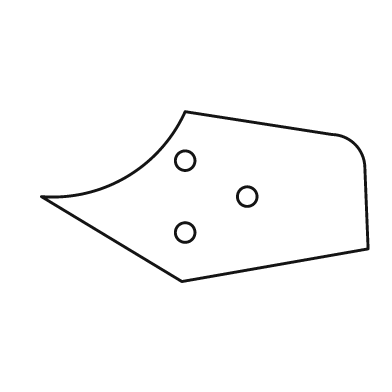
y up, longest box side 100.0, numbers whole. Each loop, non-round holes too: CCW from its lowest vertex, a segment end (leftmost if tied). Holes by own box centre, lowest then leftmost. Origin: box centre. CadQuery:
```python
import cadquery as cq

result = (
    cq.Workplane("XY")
    .moveTo(-7.0, -26.0)
    .lineTo(50.0, -16.0)
    .lineTo(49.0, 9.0)
    .threePointArc((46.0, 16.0), (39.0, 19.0))
    .lineTo(-6.0, 26.0)
    .threePointArc((-24.0, 6.0), (-50.0, 0.0))
    .close()
    .moveTo(-6.0, -11.0)
    .circle(3.0)
    .moveTo(13.0, 0.0)
    .circle(3.0)
    .moveTo(-6.0, 11.0)
    .circle(3.0)
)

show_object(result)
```